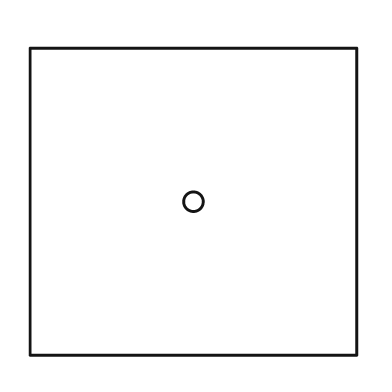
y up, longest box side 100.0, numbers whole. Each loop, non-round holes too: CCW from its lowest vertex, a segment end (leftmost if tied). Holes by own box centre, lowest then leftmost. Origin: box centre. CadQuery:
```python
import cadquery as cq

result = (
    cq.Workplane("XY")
    .moveTo(-50.0, -47.0)
    .lineTo(50.0, -47.0)
    .lineTo(50.0, 47.0)
    .lineTo(-50.0, 47.0)
    .close()
    .moveTo(0.0, 0.0)
    .circle(3.0)
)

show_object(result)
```